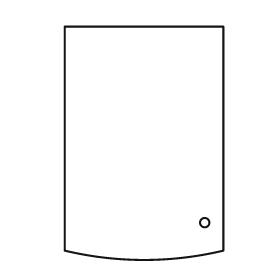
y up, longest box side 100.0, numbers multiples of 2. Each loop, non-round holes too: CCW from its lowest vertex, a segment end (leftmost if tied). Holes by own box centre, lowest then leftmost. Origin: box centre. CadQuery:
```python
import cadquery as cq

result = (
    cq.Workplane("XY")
    .moveTo(-34.0, -46.0)
    .threePointArc((0.0, -50.0), (34.0, -46.0))
    .lineTo(34.0, 50.0)
    .lineTo(-34.0, 50.0)
    .close()
    .moveTo(26.0, -34.0)
    .circle(2.0)
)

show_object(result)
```